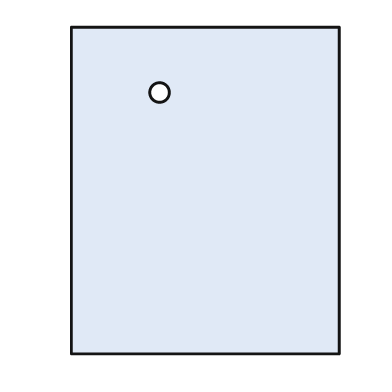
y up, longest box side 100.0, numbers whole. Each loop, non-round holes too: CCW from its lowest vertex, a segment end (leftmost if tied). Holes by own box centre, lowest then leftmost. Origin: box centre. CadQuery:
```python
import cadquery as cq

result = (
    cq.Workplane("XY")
    .moveTo(-41.0, -50.0)
    .lineTo(41.0, -50.0)
    .lineTo(41.0, 50.0)
    .lineTo(-41.0, 50.0)
    .close()
    .moveTo(-14.0, 30.0)
    .circle(3.0)
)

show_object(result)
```